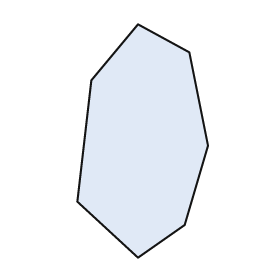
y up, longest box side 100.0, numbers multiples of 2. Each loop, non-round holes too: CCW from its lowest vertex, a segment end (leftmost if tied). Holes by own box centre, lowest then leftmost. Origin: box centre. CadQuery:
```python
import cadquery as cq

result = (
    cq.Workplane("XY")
    .moveTo(-2.0, -50.0)
    .lineTo(18.0, -36.0)
    .lineTo(28.0, -2.0)
    .lineTo(20.0, 38.0)
    .lineTo(-2.0, 50.0)
    .lineTo(-22.0, 26.0)
    .lineTo(-28.0, -26.0)
    .close()
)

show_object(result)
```